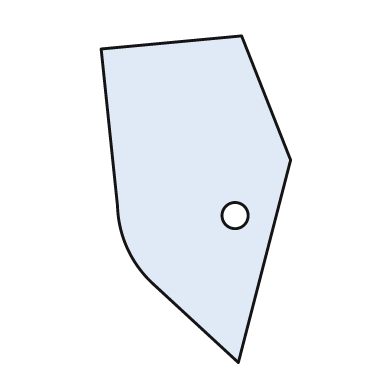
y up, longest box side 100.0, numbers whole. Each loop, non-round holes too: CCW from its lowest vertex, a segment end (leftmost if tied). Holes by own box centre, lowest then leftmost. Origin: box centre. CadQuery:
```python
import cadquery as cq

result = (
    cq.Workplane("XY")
    .moveTo(13.0, -50.0)
    .lineTo(29.0, 12.0)
    .lineTo(14.0, 50.0)
    .lineTo(-29.0, 46.0)
    .lineTo(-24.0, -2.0)
    .threePointArc((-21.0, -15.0), (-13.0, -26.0))
    .close()
    .moveTo(12.0, -5.0)
    .circle(4.0)
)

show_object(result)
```